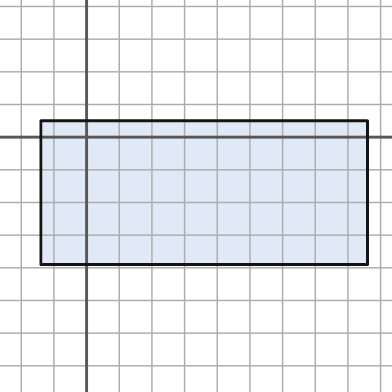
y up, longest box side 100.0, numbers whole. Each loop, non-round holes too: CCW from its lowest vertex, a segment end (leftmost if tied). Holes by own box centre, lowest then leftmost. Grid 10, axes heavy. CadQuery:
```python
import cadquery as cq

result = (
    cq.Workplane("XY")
    .moveTo(-14.0, -39.0)
    .lineTo(86.0, -39.0)
    .lineTo(86.0, 5.0)
    .lineTo(-14.0, 5.0)
    .close()
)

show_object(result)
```